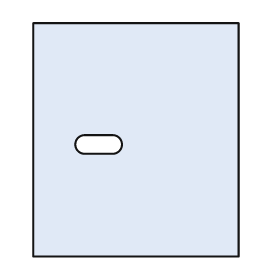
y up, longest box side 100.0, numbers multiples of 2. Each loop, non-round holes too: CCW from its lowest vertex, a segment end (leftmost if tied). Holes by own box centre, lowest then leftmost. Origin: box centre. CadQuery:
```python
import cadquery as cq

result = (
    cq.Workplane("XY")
    .moveTo(-44.0, -50.0)
    .lineTo(44.0, -50.0)
    .lineTo(44.0, 50.0)
    .lineTo(-44.0, 50.0)
    .close()
    .moveTo(-22.0, -6.0)
    .lineTo(-10.0, -6.0)
    .threePointArc((-6.0, -2.0), (-10.0, 2.0))
    .lineTo(-22.0, 2.0)
    .threePointArc((-26.0, -2.0), (-22.0, -6.0))
    .close()
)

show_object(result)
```